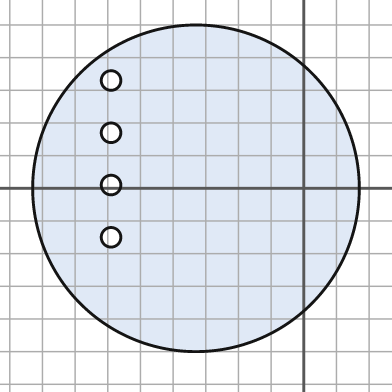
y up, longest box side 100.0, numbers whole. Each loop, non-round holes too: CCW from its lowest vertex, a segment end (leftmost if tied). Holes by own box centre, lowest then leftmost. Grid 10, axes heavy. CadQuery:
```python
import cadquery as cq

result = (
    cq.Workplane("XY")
    .moveTo(-33.0, 0.0)
    .circle(50.0)
    .moveTo(-59.0, -15.0)
    .circle(3.0)
    .moveTo(-59.0, 1.0)
    .circle(3.0)
    .moveTo(-59.0, 17.0)
    .circle(3.0)
    .moveTo(-59.0, 33.0)
    .circle(3.0)
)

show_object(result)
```